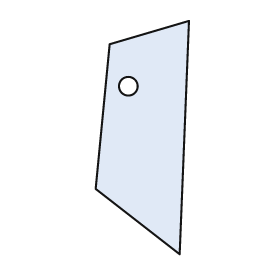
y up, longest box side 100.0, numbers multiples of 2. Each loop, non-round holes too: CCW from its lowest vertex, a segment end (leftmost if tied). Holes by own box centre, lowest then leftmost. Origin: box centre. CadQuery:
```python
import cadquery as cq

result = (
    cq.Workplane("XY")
    .moveTo(16.0, -50.0)
    .lineTo(20.0, 50.0)
    .lineTo(-14.0, 40.0)
    .lineTo(-20.0, -22.0)
    .close()
    .moveTo(-6.0, 22.0)
    .circle(4.0)
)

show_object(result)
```